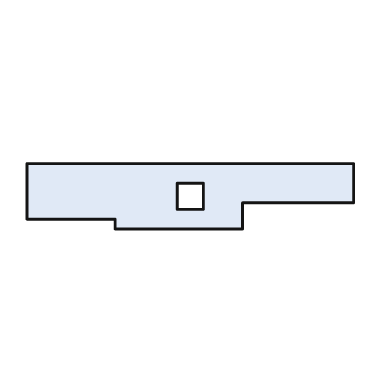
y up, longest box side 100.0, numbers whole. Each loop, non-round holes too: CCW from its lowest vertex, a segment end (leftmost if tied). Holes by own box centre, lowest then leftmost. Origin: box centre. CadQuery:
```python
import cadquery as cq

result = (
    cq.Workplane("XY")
    .moveTo(-23.0, -10.0)
    .lineTo(16.0, -10.0)
    .lineTo(16.0, -2.0)
    .lineTo(50.0, -2.0)
    .lineTo(50.0, 10.0)
    .lineTo(-50.0, 10.0)
    .lineTo(-50.0, -7.0)
    .lineTo(-23.0, -7.0)
    .close()
    .moveTo(-4.0, -4.0)
    .lineTo(4.0, -4.0)
    .lineTo(4.0, 4.0)
    .lineTo(-4.0, 4.0)
    .close()
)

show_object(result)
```